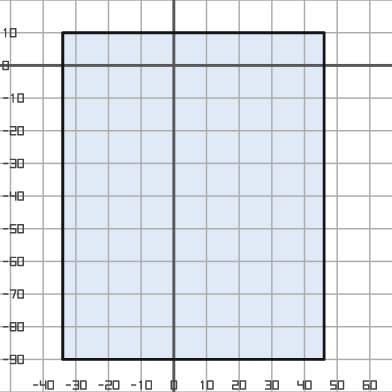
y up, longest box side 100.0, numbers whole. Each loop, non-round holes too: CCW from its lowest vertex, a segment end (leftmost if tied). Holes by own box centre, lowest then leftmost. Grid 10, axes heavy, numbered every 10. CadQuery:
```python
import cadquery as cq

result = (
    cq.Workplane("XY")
    .moveTo(-34.0, -90.0)
    .lineTo(46.0, -90.0)
    .lineTo(46.0, 10.0)
    .lineTo(-34.0, 10.0)
    .close()
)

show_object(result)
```